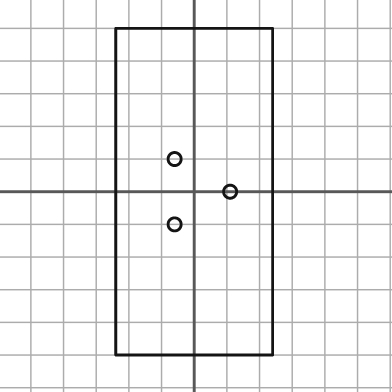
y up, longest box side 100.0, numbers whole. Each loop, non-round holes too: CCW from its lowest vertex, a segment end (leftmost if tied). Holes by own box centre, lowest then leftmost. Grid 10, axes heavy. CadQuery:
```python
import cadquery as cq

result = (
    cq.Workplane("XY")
    .moveTo(-24.0, -50.0)
    .lineTo(24.0, -50.0)
    .lineTo(24.0, 50.0)
    .lineTo(-24.0, 50.0)
    .close()
    .moveTo(-6.0, -10.0)
    .circle(2.0)
    .moveTo(11.0, 0.0)
    .circle(2.0)
    .moveTo(-6.0, 10.0)
    .circle(2.0)
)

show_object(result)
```